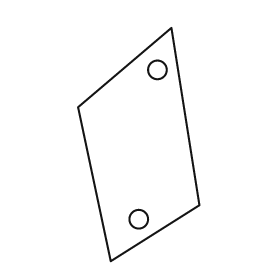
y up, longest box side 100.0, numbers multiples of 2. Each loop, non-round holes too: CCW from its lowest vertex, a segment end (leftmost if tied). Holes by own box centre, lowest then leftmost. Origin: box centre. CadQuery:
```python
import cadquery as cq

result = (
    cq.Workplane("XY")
    .moveTo(-12.0, -50.0)
    .lineTo(26.0, -26.0)
    .lineTo(14.0, 50.0)
    .lineTo(-26.0, 16.0)
    .close()
    .moveTo(0.0, -32.0)
    .circle(4.0)
    .moveTo(8.0, 32.0)
    .circle(4.0)
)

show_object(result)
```